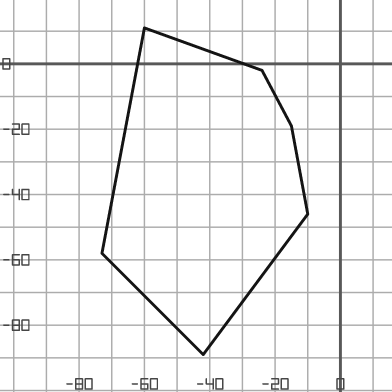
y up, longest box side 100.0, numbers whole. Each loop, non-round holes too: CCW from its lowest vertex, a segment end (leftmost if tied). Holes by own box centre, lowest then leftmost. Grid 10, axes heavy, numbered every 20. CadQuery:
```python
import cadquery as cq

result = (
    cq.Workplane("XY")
    .moveTo(-42.0, -89.0)
    .lineTo(-10.0, -46.0)
    .lineTo(-15.0, -19.0)
    .lineTo(-24.0, -2.0)
    .lineTo(-60.0, 11.0)
    .lineTo(-73.0, -58.0)
    .close()
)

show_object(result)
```